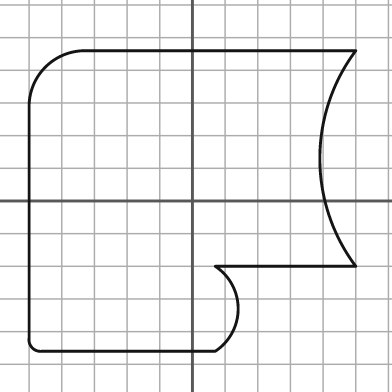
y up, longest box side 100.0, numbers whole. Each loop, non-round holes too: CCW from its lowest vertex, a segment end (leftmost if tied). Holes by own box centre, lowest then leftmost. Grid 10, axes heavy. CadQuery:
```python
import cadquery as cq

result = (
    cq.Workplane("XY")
    .moveTo(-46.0, -46.0)
    .lineTo(7.0, -46.0)
    .threePointArc((14.0, -33.0), (7.0, -20.0))
    .lineTo(50.0, -20.0)
    .threePointArc((39.0, 13.0), (50.0, 46.0))
    .lineTo(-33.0, 46.0)
    .threePointArc((-45.0, 41.0), (-50.0, 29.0))
    .lineTo(-50.0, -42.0)
    .threePointArc((-49.0, -45.0), (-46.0, -46.0))
    .close()
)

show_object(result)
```